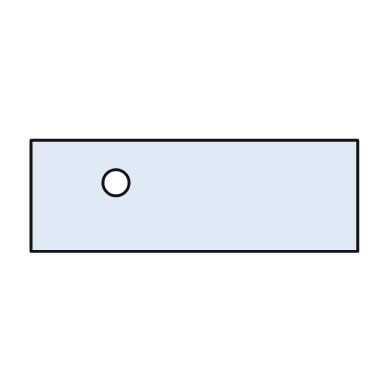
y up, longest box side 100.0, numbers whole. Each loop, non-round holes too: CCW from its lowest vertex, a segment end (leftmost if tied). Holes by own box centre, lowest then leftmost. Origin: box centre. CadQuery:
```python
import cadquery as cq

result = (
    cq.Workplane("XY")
    .moveTo(-50.0, -17.0)
    .lineTo(50.0, -17.0)
    .lineTo(50.0, 17.0)
    .lineTo(-50.0, 17.0)
    .close()
    .moveTo(-24.0, 4.0)
    .circle(4.0)
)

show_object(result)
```